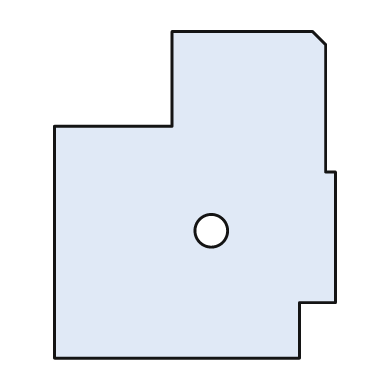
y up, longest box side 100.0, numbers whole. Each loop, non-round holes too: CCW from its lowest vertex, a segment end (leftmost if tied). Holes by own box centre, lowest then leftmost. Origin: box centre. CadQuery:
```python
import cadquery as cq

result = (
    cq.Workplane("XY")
    .moveTo(-43.0, -50.0)
    .lineTo(32.0, -50.0)
    .lineTo(32.0, -33.0)
    .lineTo(43.0, -33.0)
    .lineTo(43.0, 7.0)
    .lineTo(40.0, 7.0)
    .lineTo(40.0, 46.0)
    .lineTo(36.0, 50.0)
    .lineTo(-7.0, 50.0)
    .lineTo(-7.0, 21.0)
    .lineTo(-43.0, 21.0)
    .close()
    .moveTo(5.0, -11.0)
    .circle(5.0)
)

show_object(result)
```